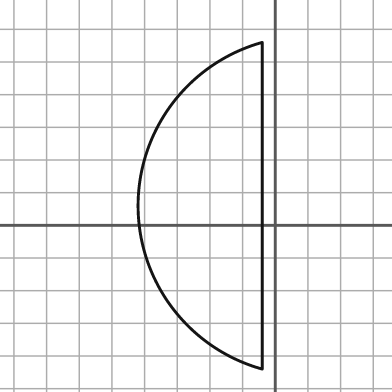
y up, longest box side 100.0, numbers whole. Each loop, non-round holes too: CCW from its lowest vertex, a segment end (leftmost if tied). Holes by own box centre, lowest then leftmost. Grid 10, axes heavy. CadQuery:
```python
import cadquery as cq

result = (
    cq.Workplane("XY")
    .moveTo(-4.0, -44.0)
    .lineTo(-4.0, 56.0)
    .threePointArc((-42.0, 6.0), (-4.0, -44.0))
    .close()
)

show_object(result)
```